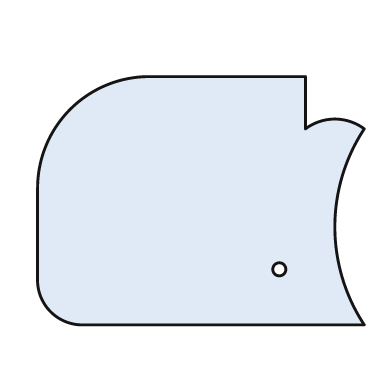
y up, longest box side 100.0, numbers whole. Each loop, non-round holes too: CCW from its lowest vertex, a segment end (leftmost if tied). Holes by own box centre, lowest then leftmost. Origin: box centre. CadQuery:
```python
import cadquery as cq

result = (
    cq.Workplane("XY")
    .moveTo(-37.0, -38.0)
    .lineTo(50.0, -38.0)
    .threePointArc((41.0, -8.0), (50.0, 22.0))
    .threePointArc((41.0, 25.0), (32.0, 22.0))
    .lineTo(32.0, 38.0)
    .lineTo(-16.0, 38.0)
    .threePointArc((-40.0, 28.0), (-50.0, 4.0))
    .lineTo(-50.0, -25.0)
    .threePointArc((-46.0, -34.0), (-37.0, -38.0))
    .close()
    .moveTo(24.0, -21.0)
    .circle(2.0)
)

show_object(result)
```